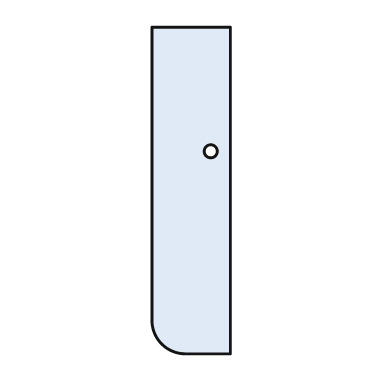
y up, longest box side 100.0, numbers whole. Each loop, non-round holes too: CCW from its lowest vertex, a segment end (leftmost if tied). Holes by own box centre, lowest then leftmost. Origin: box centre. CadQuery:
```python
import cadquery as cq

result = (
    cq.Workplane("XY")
    .moveTo(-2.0, -50.0)
    .lineTo(12.0, -50.0)
    .lineTo(12.0, 50.0)
    .lineTo(-12.0, 50.0)
    .lineTo(-12.0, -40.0)
    .threePointArc((-9.0, -47.0), (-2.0, -50.0))
    .close()
    .moveTo(6.0, 12.0)
    .circle(2.0)
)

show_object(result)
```